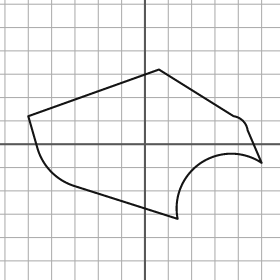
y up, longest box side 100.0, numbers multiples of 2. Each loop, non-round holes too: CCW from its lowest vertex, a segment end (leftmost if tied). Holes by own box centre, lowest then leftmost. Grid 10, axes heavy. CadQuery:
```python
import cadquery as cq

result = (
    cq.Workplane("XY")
    .moveTo(14.0, -32.0)
    .threePointArc((24.0, -8.0), (50.0, -8.0))
    .lineTo(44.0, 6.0)
    .threePointArc((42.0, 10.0), (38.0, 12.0))
    .lineTo(6.0, 32.0)
    .lineTo(-50.0, 12.0)
    .lineTo(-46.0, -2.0)
    .threePointArc((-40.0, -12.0), (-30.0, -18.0))
    .close()
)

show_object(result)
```